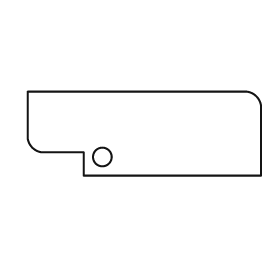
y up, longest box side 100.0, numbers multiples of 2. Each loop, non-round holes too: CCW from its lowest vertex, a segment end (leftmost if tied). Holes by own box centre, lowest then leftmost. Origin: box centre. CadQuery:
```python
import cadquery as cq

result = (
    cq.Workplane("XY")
    .moveTo(-26.0, -18.0)
    .lineTo(50.0, -18.0)
    .lineTo(50.0, 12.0)
    .threePointArc((48.0, 16.0), (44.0, 18.0))
    .lineTo(-50.0, 18.0)
    .lineTo(-50.0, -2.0)
    .threePointArc((-48.0, -6.0), (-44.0, -8.0))
    .lineTo(-26.0, -8.0)
    .close()
    .moveTo(-18.0, -10.0)
    .circle(4.0)
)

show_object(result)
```